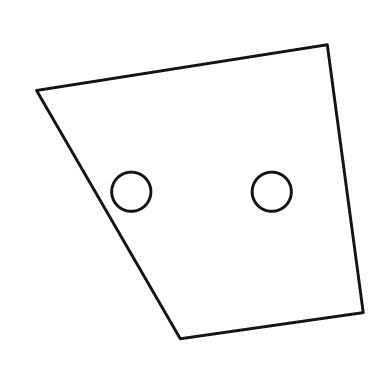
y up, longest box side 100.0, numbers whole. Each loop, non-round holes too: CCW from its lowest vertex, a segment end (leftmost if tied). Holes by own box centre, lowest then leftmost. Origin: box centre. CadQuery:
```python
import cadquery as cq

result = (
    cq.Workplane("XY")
    .moveTo(-6.0, -45.0)
    .lineTo(50.0, -37.0)
    .lineTo(39.0, 45.0)
    .lineTo(-50.0, 31.0)
    .close()
    .moveTo(-21.0, 0.0)
    .circle(6.0)
    .moveTo(22.0, 0.0)
    .circle(6.0)
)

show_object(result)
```